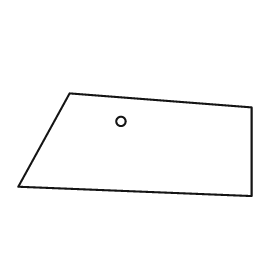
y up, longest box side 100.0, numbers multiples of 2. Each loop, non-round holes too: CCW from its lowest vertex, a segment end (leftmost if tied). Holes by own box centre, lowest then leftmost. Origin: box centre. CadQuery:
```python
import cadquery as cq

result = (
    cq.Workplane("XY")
    .moveTo(50.0, -22.0)
    .lineTo(50.0, 16.0)
    .lineTo(-28.0, 22.0)
    .lineTo(-50.0, -18.0)
    .close()
    .moveTo(-6.0, 10.0)
    .circle(2.0)
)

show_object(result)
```